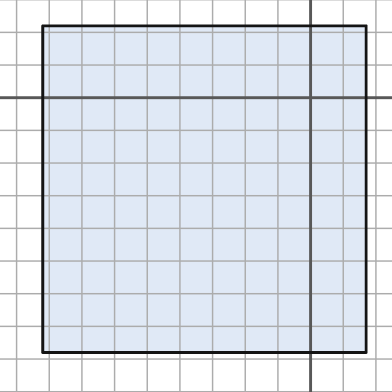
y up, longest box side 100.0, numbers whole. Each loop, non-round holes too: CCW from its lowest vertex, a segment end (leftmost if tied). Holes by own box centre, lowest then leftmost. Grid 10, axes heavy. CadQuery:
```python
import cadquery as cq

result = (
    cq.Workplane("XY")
    .moveTo(-82.0, -78.0)
    .lineTo(17.0, -78.0)
    .lineTo(17.0, 22.0)
    .lineTo(-82.0, 22.0)
    .close()
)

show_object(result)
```